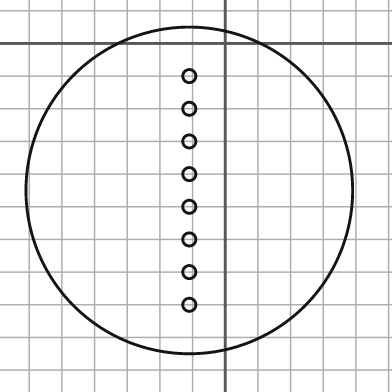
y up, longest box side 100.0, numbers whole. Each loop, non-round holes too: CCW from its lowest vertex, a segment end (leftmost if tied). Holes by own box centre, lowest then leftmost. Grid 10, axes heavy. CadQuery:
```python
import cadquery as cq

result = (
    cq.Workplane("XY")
    .moveTo(-11.0, -45.0)
    .circle(50.0)
    .moveTo(-11.0, -80.0)
    .circle(2.0)
    .moveTo(-11.0, -70.0)
    .circle(2.0)
    .moveTo(-11.0, -60.0)
    .circle(2.0)
    .moveTo(-11.0, -50.0)
    .circle(2.0)
    .moveTo(-11.0, -40.0)
    .circle(2.0)
    .moveTo(-11.0, -30.0)
    .circle(2.0)
    .moveTo(-11.0, -20.0)
    .circle(2.0)
    .moveTo(-11.0, -10.0)
    .circle(2.0)
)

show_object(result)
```